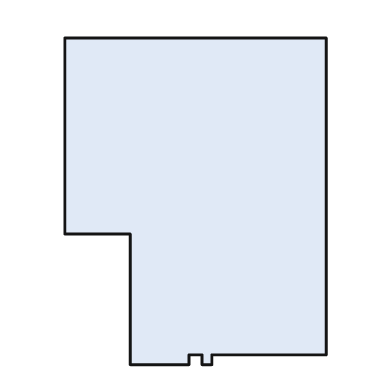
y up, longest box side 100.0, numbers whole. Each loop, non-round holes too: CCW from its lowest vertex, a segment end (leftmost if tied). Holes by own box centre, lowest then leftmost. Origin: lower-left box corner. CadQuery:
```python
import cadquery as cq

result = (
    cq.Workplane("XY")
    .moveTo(20.0, 0.0)
    .lineTo(38.0, 0.0)
    .lineTo(38.0, 3.0)
    .lineTo(42.0, 3.0)
    .lineTo(42.0, 0.0)
    .lineTo(45.0, 0.0)
    .lineTo(45.0, 3.0)
    .lineTo(80.0, 3.0)
    .lineTo(80.0, 100.0)
    .lineTo(0.0, 100.0)
    .lineTo(0.0, 40.0)
    .lineTo(20.0, 40.0)
    .close()
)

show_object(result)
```